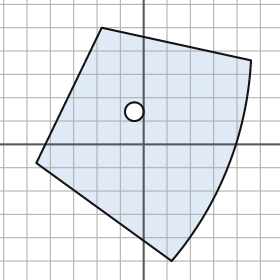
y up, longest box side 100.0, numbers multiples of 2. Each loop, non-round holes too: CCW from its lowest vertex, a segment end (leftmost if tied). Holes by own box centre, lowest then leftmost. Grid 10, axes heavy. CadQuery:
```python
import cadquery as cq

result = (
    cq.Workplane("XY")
    .moveTo(12.0, -50.0)
    .threePointArc((36.0, -10.0), (46.0, 36.0))
    .lineTo(-18.0, 50.0)
    .lineTo(-46.0, -8.0)
    .close()
    .moveTo(-4.0, 14.0)
    .circle(4.0)
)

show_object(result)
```